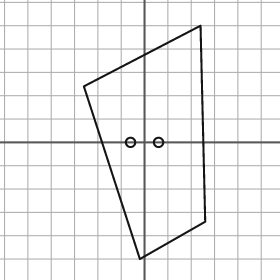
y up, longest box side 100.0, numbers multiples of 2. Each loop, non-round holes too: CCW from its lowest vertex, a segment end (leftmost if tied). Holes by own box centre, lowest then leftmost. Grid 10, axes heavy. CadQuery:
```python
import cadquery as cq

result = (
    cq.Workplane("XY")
    .moveTo(-2.0, -50.0)
    .lineTo(26.0, -34.0)
    .lineTo(24.0, 50.0)
    .lineTo(-26.0, 24.0)
    .close()
    .moveTo(-6.0, 0.0)
    .circle(2.0)
    .moveTo(6.0, 0.0)
    .circle(2.0)
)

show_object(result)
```